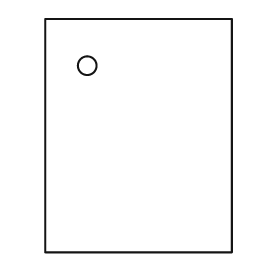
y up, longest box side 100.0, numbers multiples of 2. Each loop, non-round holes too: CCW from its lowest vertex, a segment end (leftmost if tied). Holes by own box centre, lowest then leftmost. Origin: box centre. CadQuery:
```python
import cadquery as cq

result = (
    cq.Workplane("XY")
    .moveTo(-40.0, -50.0)
    .lineTo(40.0, -50.0)
    .lineTo(40.0, 50.0)
    .lineTo(-40.0, 50.0)
    .close()
    .moveTo(-22.0, 30.0)
    .circle(4.0)
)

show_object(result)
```